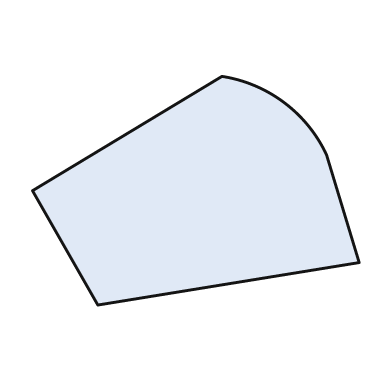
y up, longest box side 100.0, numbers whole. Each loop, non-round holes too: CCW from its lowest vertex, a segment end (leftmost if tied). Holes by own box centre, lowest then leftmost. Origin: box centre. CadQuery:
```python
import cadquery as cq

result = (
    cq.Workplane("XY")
    .moveTo(-30.0, -35.0)
    .lineTo(50.0, -22.0)
    .lineTo(40.0, 11.0)
    .threePointArc((27.0, 27.0), (8.0, 35.0))
    .lineTo(-50.0, 0.0)
    .close()
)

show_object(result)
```